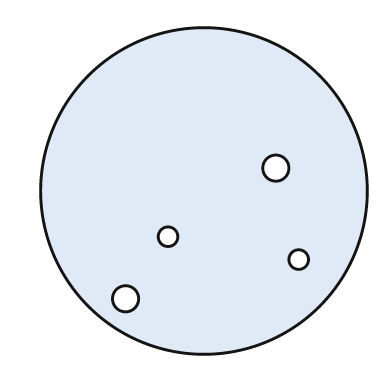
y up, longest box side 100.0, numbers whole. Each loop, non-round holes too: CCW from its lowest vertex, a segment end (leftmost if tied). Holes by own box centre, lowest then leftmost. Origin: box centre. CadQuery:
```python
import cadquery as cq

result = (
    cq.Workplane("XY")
    .moveTo(0.0, 0.0)
    .circle(50.0)
    .moveTo(-24.0, -33.0)
    .circle(4.0)
    .moveTo(29.0, -21.0)
    .circle(3.0)
    .moveTo(-11.0, -14.0)
    .circle(3.0)
    .moveTo(22.0, 7.0)
    .circle(4.0)
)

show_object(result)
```